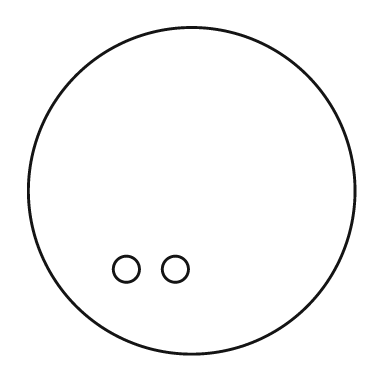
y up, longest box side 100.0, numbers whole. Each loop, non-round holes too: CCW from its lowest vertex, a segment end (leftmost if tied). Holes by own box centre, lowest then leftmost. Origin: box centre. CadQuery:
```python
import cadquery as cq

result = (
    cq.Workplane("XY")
    .moveTo(0.0, 0.0)
    .circle(50.0)
    .moveTo(-20.0, -24.0)
    .circle(4.0)
    .moveTo(-5.0, -24.0)
    .circle(4.0)
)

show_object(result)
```